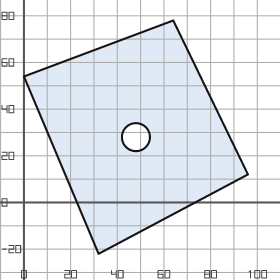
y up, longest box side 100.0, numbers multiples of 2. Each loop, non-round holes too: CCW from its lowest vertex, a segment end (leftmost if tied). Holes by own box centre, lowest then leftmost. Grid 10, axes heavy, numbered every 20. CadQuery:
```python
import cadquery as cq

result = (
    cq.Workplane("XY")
    .moveTo(32.0, -22.0)
    .lineTo(96.0, 12.0)
    .lineTo(64.0, 78.0)
    .lineTo(0.0, 54.0)
    .close()
    .moveTo(48.0, 28.0)
    .circle(6.0)
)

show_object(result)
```